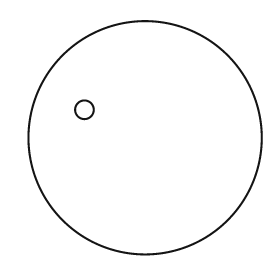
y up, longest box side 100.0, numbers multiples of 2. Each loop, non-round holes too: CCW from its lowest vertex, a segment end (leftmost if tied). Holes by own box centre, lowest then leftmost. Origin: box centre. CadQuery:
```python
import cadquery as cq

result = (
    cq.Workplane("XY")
    .moveTo(0.0, 0.0)
    .circle(50.0)
    .moveTo(-26.0, 12.0)
    .circle(4.0)
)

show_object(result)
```